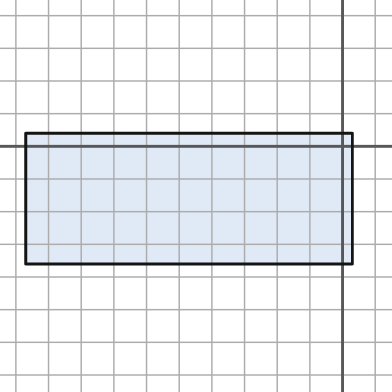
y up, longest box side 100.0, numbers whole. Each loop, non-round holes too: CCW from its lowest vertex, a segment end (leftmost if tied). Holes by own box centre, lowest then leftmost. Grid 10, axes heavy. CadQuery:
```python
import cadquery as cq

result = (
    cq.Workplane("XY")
    .moveTo(-97.0, -36.0)
    .lineTo(3.0, -36.0)
    .lineTo(3.0, 4.0)
    .lineTo(-97.0, 4.0)
    .close()
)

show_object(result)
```